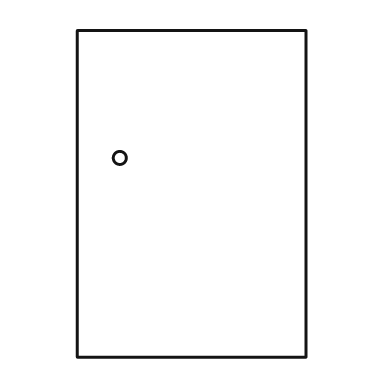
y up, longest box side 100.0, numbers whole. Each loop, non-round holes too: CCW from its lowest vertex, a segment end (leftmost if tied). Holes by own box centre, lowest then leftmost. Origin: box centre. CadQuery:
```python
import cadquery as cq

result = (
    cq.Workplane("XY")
    .moveTo(-35.0, -50.0)
    .lineTo(35.0, -50.0)
    .lineTo(35.0, 50.0)
    .lineTo(-35.0, 50.0)
    .close()
    .moveTo(-22.0, 11.0)
    .circle(2.0)
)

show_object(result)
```